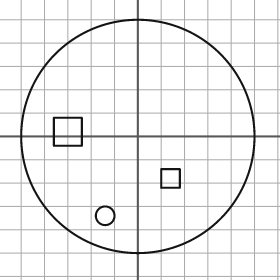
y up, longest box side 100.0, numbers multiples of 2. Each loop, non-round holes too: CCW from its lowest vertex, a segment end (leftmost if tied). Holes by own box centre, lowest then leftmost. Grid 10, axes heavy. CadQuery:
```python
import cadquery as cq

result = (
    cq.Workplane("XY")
    .moveTo(0.0, 0.0)
    .circle(50.0)
    .moveTo(-14.0, -34.0)
    .circle(4.0)
    .moveTo(10.0, -22.0)
    .lineTo(18.0, -22.0)
    .lineTo(18.0, -14.0)
    .lineTo(10.0, -14.0)
    .close()
    .moveTo(-36.0, -4.0)
    .lineTo(-24.0, -4.0)
    .lineTo(-24.0, 8.0)
    .lineTo(-36.0, 8.0)
    .close()
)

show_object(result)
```